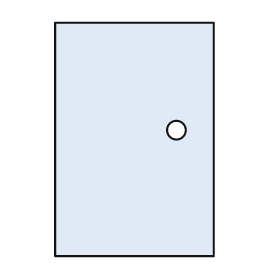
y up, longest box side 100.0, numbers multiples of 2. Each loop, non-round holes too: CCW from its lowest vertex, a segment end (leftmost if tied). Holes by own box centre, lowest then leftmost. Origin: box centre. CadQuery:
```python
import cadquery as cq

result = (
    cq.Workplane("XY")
    .moveTo(-34.0, -50.0)
    .lineTo(34.0, -50.0)
    .lineTo(34.0, 50.0)
    .lineTo(-34.0, 50.0)
    .close()
    .moveTo(18.0, 4.0)
    .circle(4.0)
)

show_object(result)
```